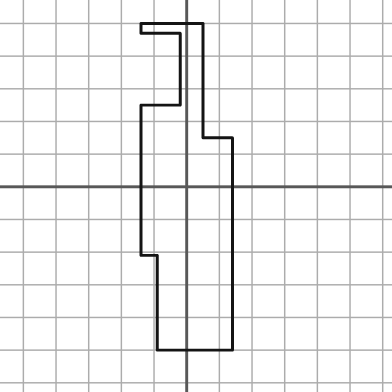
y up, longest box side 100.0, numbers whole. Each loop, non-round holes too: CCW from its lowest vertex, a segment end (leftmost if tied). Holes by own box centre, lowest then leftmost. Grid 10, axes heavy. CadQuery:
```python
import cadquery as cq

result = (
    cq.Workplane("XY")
    .moveTo(-9.0, -50.0)
    .lineTo(14.0, -50.0)
    .lineTo(14.0, 15.0)
    .lineTo(5.0, 15.0)
    .lineTo(5.0, 50.0)
    .lineTo(-14.0, 50.0)
    .lineTo(-14.0, 47.0)
    .lineTo(-2.0, 47.0)
    .lineTo(-2.0, 25.0)
    .lineTo(-14.0, 25.0)
    .lineTo(-14.0, -21.0)
    .lineTo(-9.0, -21.0)
    .close()
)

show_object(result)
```